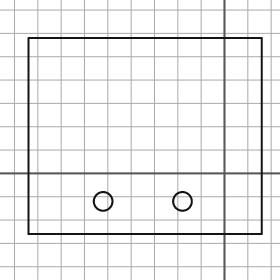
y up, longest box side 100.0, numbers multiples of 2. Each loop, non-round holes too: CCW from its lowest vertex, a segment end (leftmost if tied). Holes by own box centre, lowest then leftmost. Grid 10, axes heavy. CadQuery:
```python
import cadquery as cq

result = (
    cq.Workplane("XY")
    .moveTo(-84.0, -26.0)
    .lineTo(16.0, -26.0)
    .lineTo(16.0, 58.0)
    .lineTo(-84.0, 58.0)
    .close()
    .moveTo(-52.0, -12.0)
    .circle(4.0)
    .moveTo(-18.0, -12.0)
    .circle(4.0)
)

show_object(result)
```